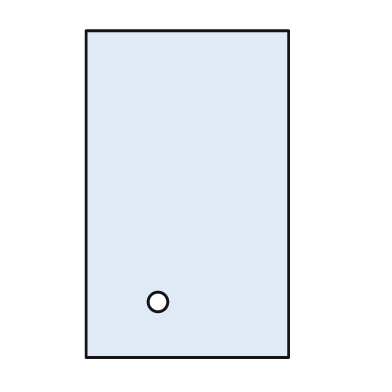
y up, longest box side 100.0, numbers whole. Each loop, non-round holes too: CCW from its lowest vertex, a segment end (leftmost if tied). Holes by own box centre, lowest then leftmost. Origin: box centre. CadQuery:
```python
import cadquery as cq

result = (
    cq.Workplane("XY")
    .moveTo(-31.0, -50.0)
    .lineTo(31.0, -50.0)
    .lineTo(31.0, 50.0)
    .lineTo(-31.0, 50.0)
    .close()
    .moveTo(-9.0, -33.0)
    .circle(3.0)
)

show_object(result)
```